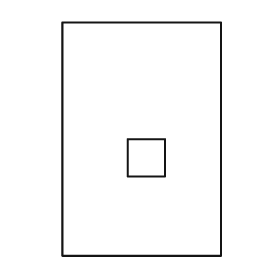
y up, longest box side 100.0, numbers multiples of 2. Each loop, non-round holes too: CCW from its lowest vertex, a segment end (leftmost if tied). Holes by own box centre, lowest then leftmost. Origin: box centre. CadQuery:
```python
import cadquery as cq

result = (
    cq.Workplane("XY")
    .moveTo(-34.0, -50.0)
    .lineTo(34.0, -50.0)
    .lineTo(34.0, 50.0)
    .lineTo(-34.0, 50.0)
    .close()
    .moveTo(-6.0, -16.0)
    .lineTo(10.0, -16.0)
    .lineTo(10.0, 0.0)
    .lineTo(-6.0, 0.0)
    .close()
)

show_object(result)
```